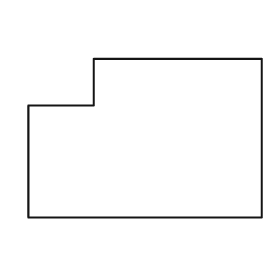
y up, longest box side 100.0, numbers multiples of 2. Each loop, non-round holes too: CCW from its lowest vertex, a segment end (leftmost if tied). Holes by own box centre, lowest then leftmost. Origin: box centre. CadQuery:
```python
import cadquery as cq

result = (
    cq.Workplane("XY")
    .moveTo(-50.0, -34.0)
    .lineTo(50.0, -34.0)
    .lineTo(50.0, 34.0)
    .lineTo(-22.0, 34.0)
    .lineTo(-22.0, 14.0)
    .lineTo(-50.0, 14.0)
    .close()
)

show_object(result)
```